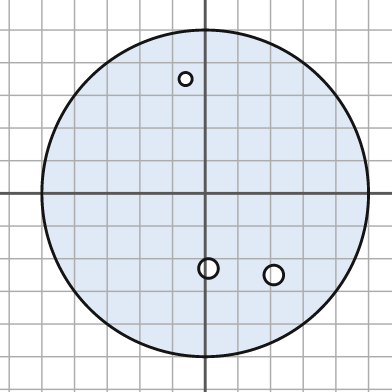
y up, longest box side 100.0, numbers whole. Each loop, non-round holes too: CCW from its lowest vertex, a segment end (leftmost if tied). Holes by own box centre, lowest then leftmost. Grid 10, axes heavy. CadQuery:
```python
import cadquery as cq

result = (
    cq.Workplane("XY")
    .moveTo(0.0, 0.0)
    .circle(50.0)
    .moveTo(21.0, -25.0)
    .circle(3.0)
    .moveTo(1.0, -23.0)
    .circle(3.0)
    .moveTo(-6.0, 35.0)
    .circle(2.0)
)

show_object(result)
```